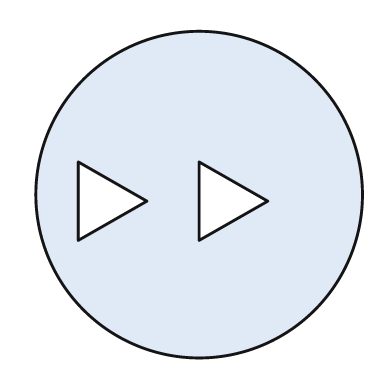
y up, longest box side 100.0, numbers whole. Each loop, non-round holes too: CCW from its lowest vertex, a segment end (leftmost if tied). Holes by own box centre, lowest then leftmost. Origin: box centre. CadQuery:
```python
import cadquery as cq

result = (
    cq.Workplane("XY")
    .moveTo(0.0, 0.0)
    .circle(50.0)
    .moveTo(-37.0, -14.0)
    .lineTo(-16.0, -2.0)
    .lineTo(-37.0, 10.0)
    .close()
    .moveTo(0.0, -14.0)
    .lineTo(21.0, -2.0)
    .lineTo(0.0, 10.0)
    .close()
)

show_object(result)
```